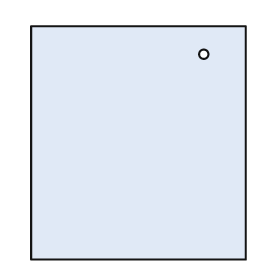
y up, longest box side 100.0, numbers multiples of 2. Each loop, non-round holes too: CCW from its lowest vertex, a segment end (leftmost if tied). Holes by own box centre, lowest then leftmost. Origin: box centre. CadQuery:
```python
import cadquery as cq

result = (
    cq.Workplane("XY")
    .moveTo(-46.0, -50.0)
    .lineTo(46.0, -50.0)
    .lineTo(46.0, 50.0)
    .lineTo(-46.0, 50.0)
    .close()
    .moveTo(28.0, 38.0)
    .circle(2.0)
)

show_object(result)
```